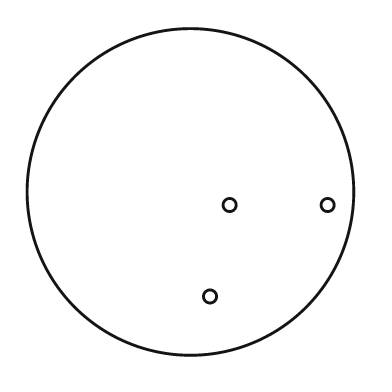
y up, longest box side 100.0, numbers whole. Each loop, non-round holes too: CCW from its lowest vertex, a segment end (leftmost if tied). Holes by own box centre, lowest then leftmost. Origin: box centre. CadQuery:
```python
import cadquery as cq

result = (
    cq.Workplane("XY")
    .moveTo(0.0, 0.0)
    .circle(50.0)
    .moveTo(6.0, -32.0)
    .circle(2.0)
    .moveTo(12.0, -4.0)
    .circle(2.0)
    .moveTo(42.0, -4.0)
    .circle(2.0)
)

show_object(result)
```